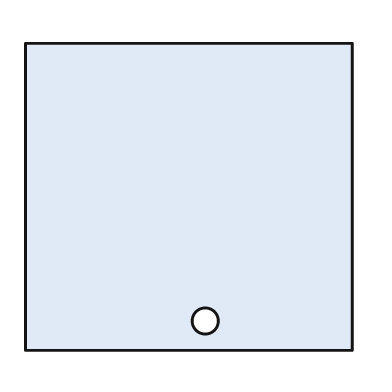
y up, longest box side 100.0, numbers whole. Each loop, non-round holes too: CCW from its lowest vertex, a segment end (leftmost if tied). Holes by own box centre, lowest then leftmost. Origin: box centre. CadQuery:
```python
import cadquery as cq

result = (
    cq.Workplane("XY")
    .moveTo(-50.0, -47.0)
    .lineTo(50.0, -47.0)
    .lineTo(50.0, 47.0)
    .lineTo(-50.0, 47.0)
    .close()
    .moveTo(5.0, -38.0)
    .circle(4.0)
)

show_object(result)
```